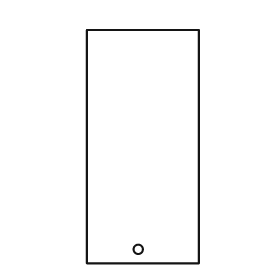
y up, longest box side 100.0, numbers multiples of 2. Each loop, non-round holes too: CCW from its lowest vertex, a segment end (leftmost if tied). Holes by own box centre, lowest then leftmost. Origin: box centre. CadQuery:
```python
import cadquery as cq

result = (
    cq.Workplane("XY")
    .moveTo(-24.0, -50.0)
    .lineTo(24.0, -50.0)
    .lineTo(24.0, 50.0)
    .lineTo(-24.0, 50.0)
    .close()
    .moveTo(-2.0, -44.0)
    .circle(2.0)
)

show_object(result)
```